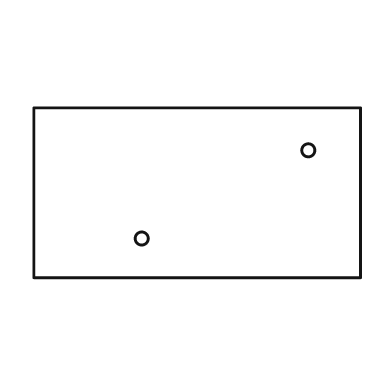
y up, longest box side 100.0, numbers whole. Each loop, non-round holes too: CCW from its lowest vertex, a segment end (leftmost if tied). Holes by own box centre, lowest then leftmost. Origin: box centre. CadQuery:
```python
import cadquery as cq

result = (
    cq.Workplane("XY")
    .moveTo(-50.0, -26.0)
    .lineTo(50.0, -26.0)
    .lineTo(50.0, 26.0)
    .lineTo(-50.0, 26.0)
    .close()
    .moveTo(-17.0, -14.0)
    .circle(2.0)
    .moveTo(34.0, 13.0)
    .circle(2.0)
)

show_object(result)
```